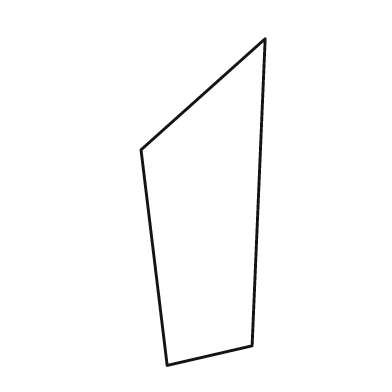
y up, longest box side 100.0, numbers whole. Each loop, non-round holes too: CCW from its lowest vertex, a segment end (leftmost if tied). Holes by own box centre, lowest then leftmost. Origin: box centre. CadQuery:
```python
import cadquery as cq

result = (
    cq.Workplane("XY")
    .moveTo(-11.0, -50.0)
    .lineTo(15.0, -44.0)
    .lineTo(19.0, 50.0)
    .lineTo(-19.0, 16.0)
    .close()
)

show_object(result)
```